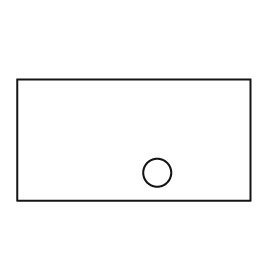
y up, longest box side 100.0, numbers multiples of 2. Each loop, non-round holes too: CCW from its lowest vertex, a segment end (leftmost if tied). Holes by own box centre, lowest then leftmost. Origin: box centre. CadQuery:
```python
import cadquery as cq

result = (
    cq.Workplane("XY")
    .moveTo(-50.0, -26.0)
    .lineTo(50.0, -26.0)
    .lineTo(50.0, 26.0)
    .lineTo(-50.0, 26.0)
    .close()
    .moveTo(10.0, -14.0)
    .circle(6.0)
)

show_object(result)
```